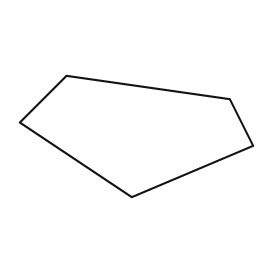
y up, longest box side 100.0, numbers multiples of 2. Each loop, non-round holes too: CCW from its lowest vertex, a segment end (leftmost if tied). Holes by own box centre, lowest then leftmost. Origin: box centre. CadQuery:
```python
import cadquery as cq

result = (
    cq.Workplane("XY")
    .moveTo(-2.0, -26.0)
    .lineTo(50.0, -4.0)
    .lineTo(40.0, 16.0)
    .lineTo(-30.0, 26.0)
    .lineTo(-50.0, 6.0)
    .close()
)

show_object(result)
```